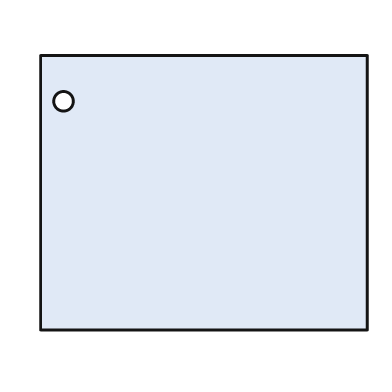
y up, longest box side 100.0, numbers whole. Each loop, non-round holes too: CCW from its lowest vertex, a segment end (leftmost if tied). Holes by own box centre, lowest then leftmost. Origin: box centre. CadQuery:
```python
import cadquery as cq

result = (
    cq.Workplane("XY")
    .moveTo(-50.0, -42.0)
    .lineTo(50.0, -42.0)
    .lineTo(50.0, 42.0)
    .lineTo(-50.0, 42.0)
    .close()
    .moveTo(-43.0, 28.0)
    .circle(3.0)
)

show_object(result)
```